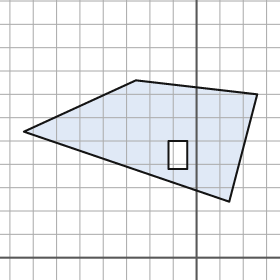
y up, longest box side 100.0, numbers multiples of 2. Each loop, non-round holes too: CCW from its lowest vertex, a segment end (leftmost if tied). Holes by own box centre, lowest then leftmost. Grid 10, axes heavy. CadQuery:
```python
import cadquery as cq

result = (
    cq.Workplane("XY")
    .moveTo(14.0, 24.0)
    .lineTo(26.0, 70.0)
    .lineTo(-26.0, 76.0)
    .lineTo(-74.0, 54.0)
    .close()
    .moveTo(-12.0, 38.0)
    .lineTo(-4.0, 38.0)
    .lineTo(-4.0, 50.0)
    .lineTo(-12.0, 50.0)
    .close()
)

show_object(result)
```